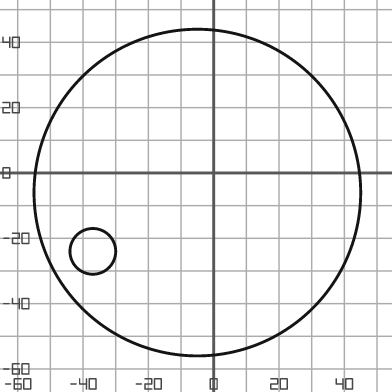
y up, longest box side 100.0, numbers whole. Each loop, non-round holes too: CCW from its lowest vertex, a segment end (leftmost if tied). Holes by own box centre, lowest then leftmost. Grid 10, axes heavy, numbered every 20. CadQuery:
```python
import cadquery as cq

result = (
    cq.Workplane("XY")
    .moveTo(-5.0, -6.0)
    .circle(50.0)
    .moveTo(-37.0, -24.0)
    .circle(7.0)
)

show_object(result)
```